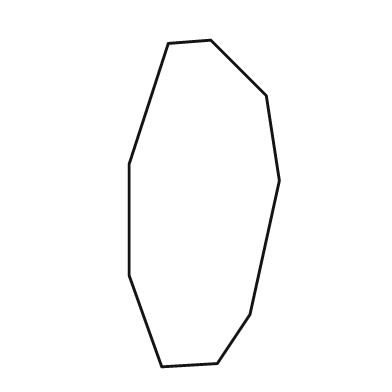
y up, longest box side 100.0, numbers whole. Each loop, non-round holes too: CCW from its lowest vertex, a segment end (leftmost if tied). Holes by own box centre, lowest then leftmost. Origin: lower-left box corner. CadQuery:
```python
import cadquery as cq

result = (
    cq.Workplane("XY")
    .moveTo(10.0, 0.0)
    .lineTo(27.0, 1.0)
    .lineTo(37.0, 16.0)
    .lineTo(46.0, 57.0)
    .lineTo(42.0, 83.0)
    .lineTo(25.0, 100.0)
    .lineTo(12.0, 99.0)
    .lineTo(0.0, 62.0)
    .lineTo(0.0, 28.0)
    .close()
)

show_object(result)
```